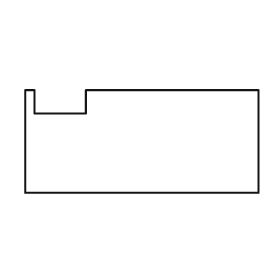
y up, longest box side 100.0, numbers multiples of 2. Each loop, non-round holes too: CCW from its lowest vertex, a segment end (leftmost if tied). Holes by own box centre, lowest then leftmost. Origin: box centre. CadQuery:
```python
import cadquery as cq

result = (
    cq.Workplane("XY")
    .moveTo(-50.0, -22.0)
    .lineTo(50.0, -22.0)
    .lineTo(50.0, 22.0)
    .lineTo(-24.0, 22.0)
    .lineTo(-24.0, 12.0)
    .lineTo(-46.0, 12.0)
    .lineTo(-46.0, 22.0)
    .lineTo(-50.0, 22.0)
    .close()
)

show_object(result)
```